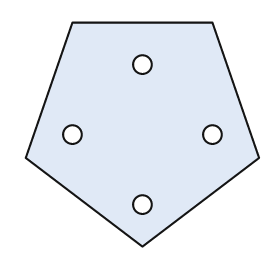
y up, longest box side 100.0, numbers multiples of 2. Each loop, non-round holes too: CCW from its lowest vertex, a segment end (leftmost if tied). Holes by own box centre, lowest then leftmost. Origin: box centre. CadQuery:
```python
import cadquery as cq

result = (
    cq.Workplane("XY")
    .moveTo(0.0, -48.0)
    .lineTo(50.0, -10.0)
    .lineTo(30.0, 48.0)
    .lineTo(-30.0, 48.0)
    .lineTo(-50.0, -10.0)
    .close()
    .moveTo(0.0, -30.0)
    .circle(4.0)
    .moveTo(-30.0, 0.0)
    .circle(4.0)
    .moveTo(30.0, 0.0)
    .circle(4.0)
    .moveTo(0.0, 30.0)
    .circle(4.0)
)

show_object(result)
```